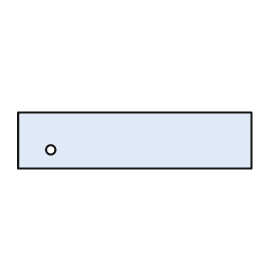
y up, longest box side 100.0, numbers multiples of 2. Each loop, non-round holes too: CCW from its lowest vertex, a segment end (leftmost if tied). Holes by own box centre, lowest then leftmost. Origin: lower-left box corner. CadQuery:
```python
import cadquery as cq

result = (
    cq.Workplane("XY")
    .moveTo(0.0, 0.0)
    .lineTo(100.0, 0.0)
    .lineTo(100.0, 24.0)
    .lineTo(0.0, 24.0)
    .close()
    .moveTo(14.0, 8.0)
    .circle(2.0)
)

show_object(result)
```